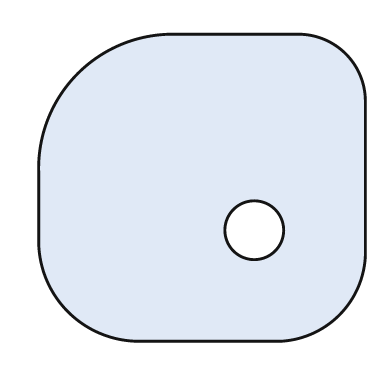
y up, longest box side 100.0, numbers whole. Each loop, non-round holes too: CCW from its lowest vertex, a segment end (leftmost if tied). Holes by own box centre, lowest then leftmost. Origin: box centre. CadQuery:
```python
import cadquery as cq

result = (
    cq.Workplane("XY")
    .moveTo(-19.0, -47.0)
    .lineTo(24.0, -47.0)
    .threePointArc((42.0, -39.0), (50.0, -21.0))
    .lineTo(50.0, 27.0)
    .threePointArc((44.0, 41.0), (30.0, 47.0))
    .lineTo(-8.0, 47.0)
    .threePointArc((-38.0, 35.0), (-50.0, 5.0))
    .lineTo(-50.0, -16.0)
    .threePointArc((-41.0, -38.0), (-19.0, -47.0))
    .close()
    .moveTo(16.0, -13.0)
    .circle(9.0)
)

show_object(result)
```